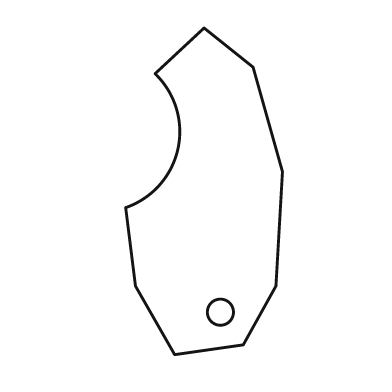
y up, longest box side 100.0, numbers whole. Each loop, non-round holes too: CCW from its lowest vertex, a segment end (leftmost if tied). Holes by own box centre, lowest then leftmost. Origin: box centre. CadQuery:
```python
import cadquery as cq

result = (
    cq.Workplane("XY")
    .moveTo(-9.0, -50.0)
    .lineTo(12.0, -47.0)
    .lineTo(22.0, -29.0)
    .lineTo(24.0, 6.0)
    .lineTo(15.0, 38.0)
    .lineTo(0.0, 50.0)
    .lineTo(-15.0, 36.0)
    .threePointArc((-8.0, 13.0), (-24.0, -5.0))
    .lineTo(-21.0, -29.0)
    .close()
    .moveTo(5.0, -37.0)
    .circle(4.0)
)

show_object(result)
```